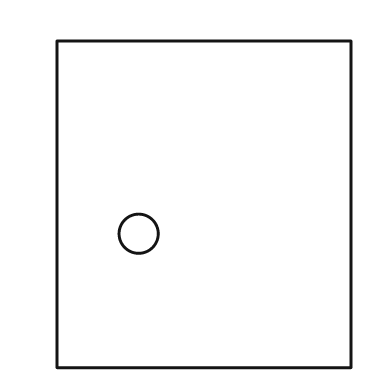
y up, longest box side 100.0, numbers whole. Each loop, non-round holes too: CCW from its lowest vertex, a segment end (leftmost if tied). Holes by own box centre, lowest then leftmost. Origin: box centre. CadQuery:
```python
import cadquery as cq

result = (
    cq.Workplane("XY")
    .moveTo(-45.0, -50.0)
    .lineTo(45.0, -50.0)
    .lineTo(45.0, 50.0)
    .lineTo(-45.0, 50.0)
    .close()
    .moveTo(-20.0, -9.0)
    .circle(6.0)
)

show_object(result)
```